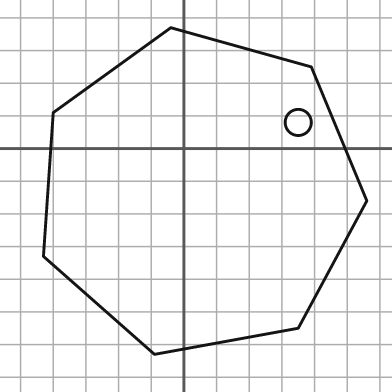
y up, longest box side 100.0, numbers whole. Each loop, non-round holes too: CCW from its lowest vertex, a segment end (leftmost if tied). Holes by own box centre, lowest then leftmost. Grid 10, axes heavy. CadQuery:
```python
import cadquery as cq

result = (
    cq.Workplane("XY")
    .moveTo(-9.0, -63.0)
    .lineTo(35.0, -55.0)
    .lineTo(56.0, -16.0)
    .lineTo(39.0, 25.0)
    .lineTo(-4.0, 37.0)
    .lineTo(-40.0, 11.0)
    .lineTo(-43.0, -33.0)
    .close()
    .moveTo(35.0, 8.0)
    .circle(4.0)
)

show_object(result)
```